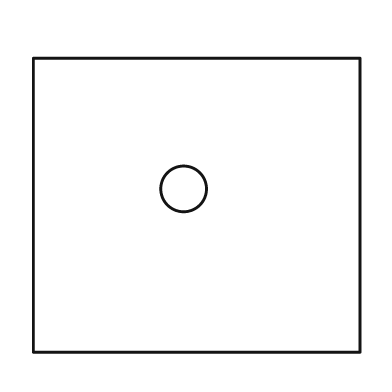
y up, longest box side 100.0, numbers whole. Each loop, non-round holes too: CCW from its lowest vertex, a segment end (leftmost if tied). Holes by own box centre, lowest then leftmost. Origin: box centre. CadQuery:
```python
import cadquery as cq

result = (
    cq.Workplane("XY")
    .moveTo(-50.0, -45.0)
    .lineTo(50.0, -45.0)
    .lineTo(50.0, 45.0)
    .lineTo(-50.0, 45.0)
    .close()
    .moveTo(-4.0, 5.0)
    .circle(7.0)
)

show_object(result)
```